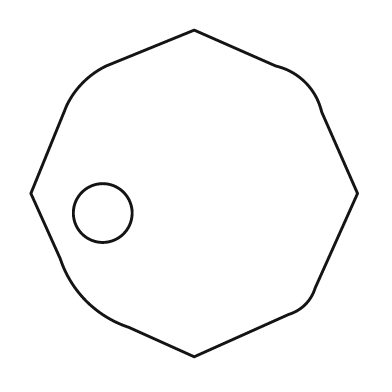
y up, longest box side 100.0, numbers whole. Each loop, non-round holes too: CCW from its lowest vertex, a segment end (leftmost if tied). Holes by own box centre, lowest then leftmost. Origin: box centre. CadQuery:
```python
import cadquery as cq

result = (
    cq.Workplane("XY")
    .moveTo(0.0, -50.0)
    .lineTo(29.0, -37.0)
    .threePointArc((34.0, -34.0), (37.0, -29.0))
    .lineTo(50.0, 0.0)
    .lineTo(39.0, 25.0)
    .threePointArc((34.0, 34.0), (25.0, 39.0))
    .lineTo(0.0, 50.0)
    .lineTo(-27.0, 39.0)
    .threePointArc((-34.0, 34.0), (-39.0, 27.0))
    .lineTo(-50.0, 0.0)
    .lineTo(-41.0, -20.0)
    .threePointArc((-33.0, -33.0), (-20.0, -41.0))
    .close()
    .moveTo(-28.0, -6.0)
    .circle(9.0)
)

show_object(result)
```